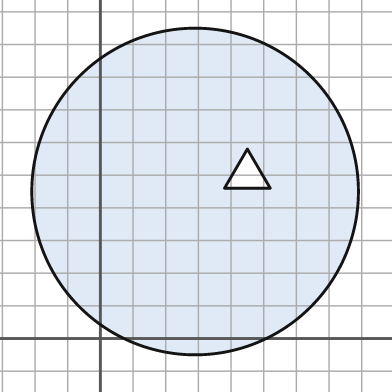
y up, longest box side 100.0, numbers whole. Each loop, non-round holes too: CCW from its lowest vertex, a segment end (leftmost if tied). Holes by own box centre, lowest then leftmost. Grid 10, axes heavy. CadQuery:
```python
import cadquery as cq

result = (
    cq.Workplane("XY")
    .moveTo(29.0, 45.0)
    .circle(50.0)
    .moveTo(38.0, 46.0)
    .lineTo(52.0, 46.0)
    .lineTo(45.0, 58.0)
    .close()
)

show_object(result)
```